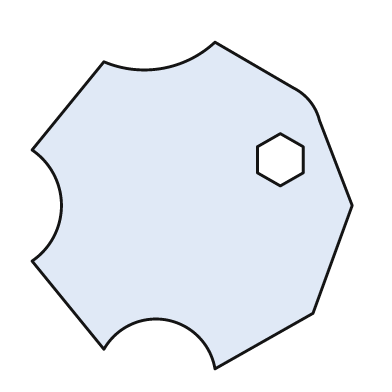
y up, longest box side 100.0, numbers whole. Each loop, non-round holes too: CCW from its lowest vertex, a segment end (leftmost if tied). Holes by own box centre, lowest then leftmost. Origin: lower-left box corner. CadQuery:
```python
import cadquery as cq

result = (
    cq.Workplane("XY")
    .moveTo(56.0, 0.0)
    .lineTo(86.0, 17.0)
    .lineTo(98.0, 50.0)
    .lineTo(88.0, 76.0)
    .threePointArc((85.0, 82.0), (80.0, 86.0))
    .lineTo(56.0, 100.0)
    .threePointArc((40.0, 92.0), (22.0, 94.0))
    .lineTo(0.0, 67.0)
    .threePointArc((9.0, 50.0), (0.0, 33.0))
    .lineTo(22.0, 6.0)
    .threePointArc((41.0, 15.0), (56.0, 0.0))
    .close()
    .moveTo(76.0, 56.0)
    .lineTo(83.0, 60.0)
    .lineTo(83.0, 68.0)
    .lineTo(76.0, 72.0)
    .lineTo(69.0, 68.0)
    .lineTo(69.0, 60.0)
    .close()
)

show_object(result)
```